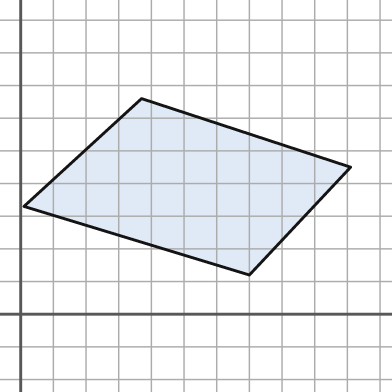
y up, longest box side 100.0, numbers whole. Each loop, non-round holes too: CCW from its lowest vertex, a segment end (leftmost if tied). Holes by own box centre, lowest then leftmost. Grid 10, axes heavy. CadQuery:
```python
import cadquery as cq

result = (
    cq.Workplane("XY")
    .moveTo(70.0, 12.0)
    .lineTo(101.0, 45.0)
    .lineTo(37.0, 66.0)
    .lineTo(1.0, 33.0)
    .close()
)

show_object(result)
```